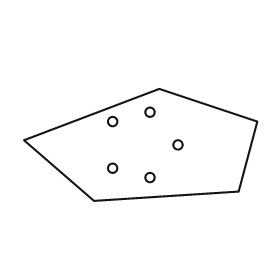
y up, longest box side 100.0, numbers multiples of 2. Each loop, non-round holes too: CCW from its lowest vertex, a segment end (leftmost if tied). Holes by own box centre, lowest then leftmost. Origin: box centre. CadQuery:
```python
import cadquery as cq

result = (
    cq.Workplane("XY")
    .moveTo(-20.0, -24.0)
    .lineTo(42.0, -20.0)
    .lineTo(50.0, 10.0)
    .lineTo(8.0, 24.0)
    .lineTo(-50.0, 2.0)
    .close()
    .moveTo(4.0, -14.0)
    .circle(2.0)
    .moveTo(-12.0, -10.0)
    .circle(2.0)
    .moveTo(16.0, 0.0)
    .circle(2.0)
    .moveTo(-12.0, 10.0)
    .circle(2.0)
    .moveTo(4.0, 14.0)
    .circle(2.0)
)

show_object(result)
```